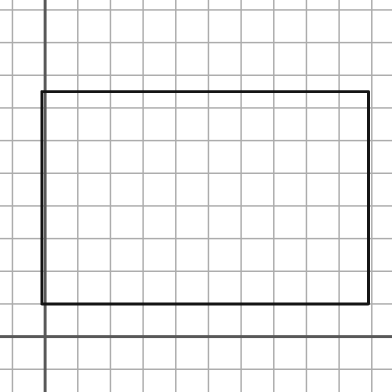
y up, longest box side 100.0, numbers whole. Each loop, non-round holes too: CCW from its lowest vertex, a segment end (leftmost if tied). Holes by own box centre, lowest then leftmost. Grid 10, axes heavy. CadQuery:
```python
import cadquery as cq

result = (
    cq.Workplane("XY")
    .moveTo(-1.0, 10.0)
    .lineTo(99.0, 10.0)
    .lineTo(99.0, 75.0)
    .lineTo(-1.0, 75.0)
    .close()
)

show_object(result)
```